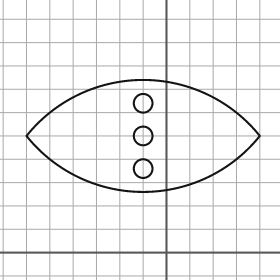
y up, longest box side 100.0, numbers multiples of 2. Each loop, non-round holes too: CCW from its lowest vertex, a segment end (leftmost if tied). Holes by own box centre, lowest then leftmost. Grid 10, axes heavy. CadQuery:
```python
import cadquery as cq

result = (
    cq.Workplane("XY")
    .moveTo(-60.0, 50.0)
    .threePointArc((-10.0, 26.0), (40.0, 50.0))
    .threePointArc((-10.0, 74.0), (-60.0, 50.0))
    .close()
    .moveTo(-10.0, 36.0)
    .circle(4.0)
    .moveTo(-10.0, 50.0)
    .circle(4.0)
    .moveTo(-10.0, 64.0)
    .circle(4.0)
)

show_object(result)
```